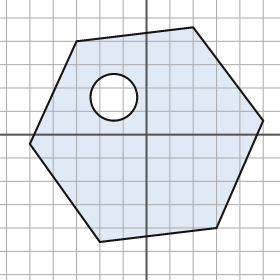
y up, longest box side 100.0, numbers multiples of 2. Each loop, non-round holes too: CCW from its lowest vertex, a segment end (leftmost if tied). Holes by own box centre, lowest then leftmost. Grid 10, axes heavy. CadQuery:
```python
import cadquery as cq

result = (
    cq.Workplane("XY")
    .moveTo(-20.0, -46.0)
    .lineTo(30.0, -40.0)
    .lineTo(50.0, 6.0)
    .lineTo(20.0, 46.0)
    .lineTo(-30.0, 40.0)
    .lineTo(-50.0, -4.0)
    .close()
    .moveTo(-14.0, 16.0)
    .circle(10.0)
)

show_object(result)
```